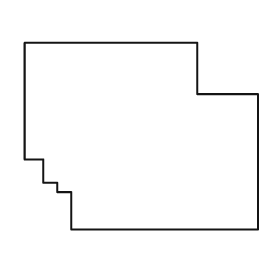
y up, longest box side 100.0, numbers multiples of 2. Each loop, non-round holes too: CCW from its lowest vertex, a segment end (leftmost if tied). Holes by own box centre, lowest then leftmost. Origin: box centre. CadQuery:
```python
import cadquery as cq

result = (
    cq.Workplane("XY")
    .moveTo(-30.0, -40.0)
    .lineTo(50.0, -40.0)
    .lineTo(50.0, 18.0)
    .lineTo(24.0, 18.0)
    .lineTo(24.0, 40.0)
    .lineTo(-50.0, 40.0)
    .lineTo(-50.0, -10.0)
    .lineTo(-42.0, -10.0)
    .lineTo(-42.0, -20.0)
    .lineTo(-36.0, -20.0)
    .lineTo(-36.0, -24.0)
    .lineTo(-30.0, -24.0)
    .close()
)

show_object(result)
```